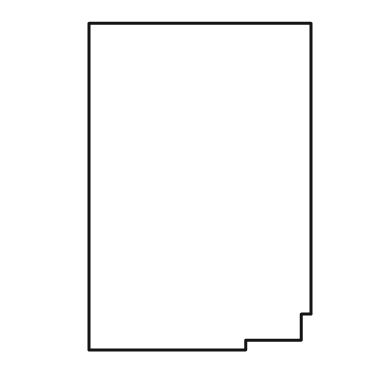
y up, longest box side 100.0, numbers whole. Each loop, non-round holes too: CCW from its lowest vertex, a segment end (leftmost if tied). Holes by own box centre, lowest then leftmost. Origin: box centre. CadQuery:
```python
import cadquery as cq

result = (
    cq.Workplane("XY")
    .moveTo(-34.0, -50.0)
    .lineTo(14.0, -50.0)
    .lineTo(14.0, -47.0)
    .lineTo(31.0, -47.0)
    .lineTo(31.0, -39.0)
    .lineTo(34.0, -39.0)
    .lineTo(34.0, 50.0)
    .lineTo(-34.0, 50.0)
    .close()
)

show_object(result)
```